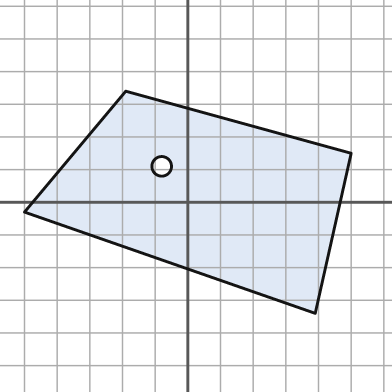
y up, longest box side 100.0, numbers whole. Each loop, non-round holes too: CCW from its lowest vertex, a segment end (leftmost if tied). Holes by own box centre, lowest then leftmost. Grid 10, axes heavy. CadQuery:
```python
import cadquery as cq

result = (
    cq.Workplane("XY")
    .moveTo(39.0, -34.0)
    .lineTo(50.0, 15.0)
    .lineTo(-19.0, 34.0)
    .lineTo(-50.0, -3.0)
    .close()
    .moveTo(-8.0, 11.0)
    .circle(3.0)
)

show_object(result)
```